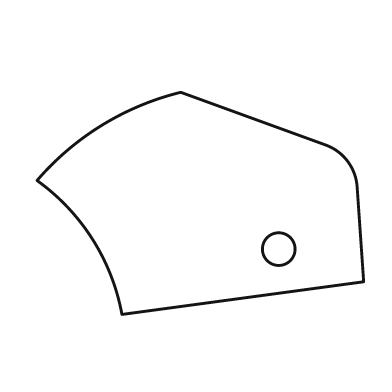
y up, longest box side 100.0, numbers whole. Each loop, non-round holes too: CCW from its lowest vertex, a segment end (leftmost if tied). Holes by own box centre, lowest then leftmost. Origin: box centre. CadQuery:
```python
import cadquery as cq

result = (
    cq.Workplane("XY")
    .moveTo(-24.0, -34.0)
    .lineTo(50.0, -24.0)
    .lineTo(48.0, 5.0)
    .threePointArc((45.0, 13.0), (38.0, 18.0))
    .lineTo(-6.0, 34.0)
    .threePointArc((-30.0, 24.0), (-50.0, 7.0))
    .threePointArc((-33.0, -11.0), (-24.0, -34.0))
    .close()
    .moveTo(24.0, -14.0)
    .circle(5.0)
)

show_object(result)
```